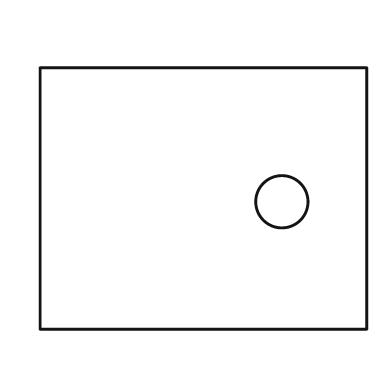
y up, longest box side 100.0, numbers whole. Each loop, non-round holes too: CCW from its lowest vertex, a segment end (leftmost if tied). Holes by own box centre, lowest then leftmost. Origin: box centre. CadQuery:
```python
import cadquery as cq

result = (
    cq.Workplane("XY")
    .moveTo(-50.0, -40.0)
    .lineTo(50.0, -40.0)
    .lineTo(50.0, 40.0)
    .lineTo(-50.0, 40.0)
    .close()
    .moveTo(24.0, -1.0)
    .circle(8.0)
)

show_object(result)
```